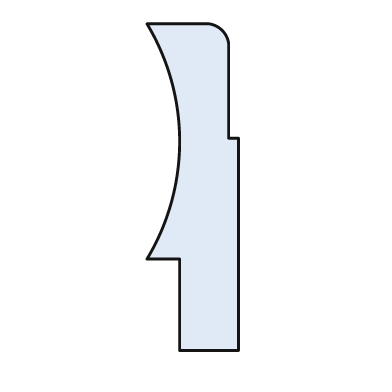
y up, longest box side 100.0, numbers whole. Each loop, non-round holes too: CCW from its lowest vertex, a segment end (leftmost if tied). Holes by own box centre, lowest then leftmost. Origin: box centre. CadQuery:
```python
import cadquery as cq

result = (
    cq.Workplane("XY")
    .moveTo(-4.0, -50.0)
    .lineTo(14.0, -50.0)
    .lineTo(14.0, 15.0)
    .lineTo(11.0, 15.0)
    .lineTo(11.0, 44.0)
    .threePointArc((9.0, 48.0), (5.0, 50.0))
    .lineTo(-14.0, 50.0)
    .threePointArc((-4.0, 14.0), (-14.0, -22.0))
    .lineTo(-4.0, -22.0)
    .close()
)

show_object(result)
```